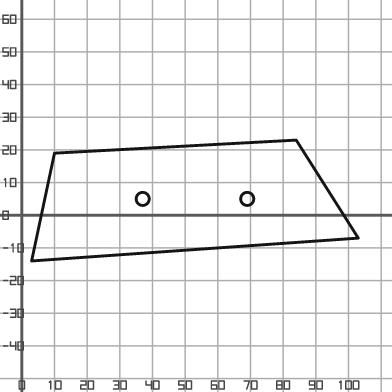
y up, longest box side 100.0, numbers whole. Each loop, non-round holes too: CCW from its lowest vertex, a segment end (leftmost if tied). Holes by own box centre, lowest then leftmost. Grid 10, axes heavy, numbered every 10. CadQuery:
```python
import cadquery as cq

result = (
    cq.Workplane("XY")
    .moveTo(3.0, -14.0)
    .lineTo(103.0, -7.0)
    .lineTo(84.0, 23.0)
    .lineTo(10.0, 19.0)
    .close()
    .moveTo(37.0, 5.0)
    .circle(2.0)
    .moveTo(69.0, 5.0)
    .circle(2.0)
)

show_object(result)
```